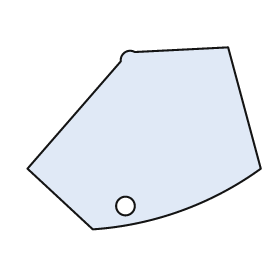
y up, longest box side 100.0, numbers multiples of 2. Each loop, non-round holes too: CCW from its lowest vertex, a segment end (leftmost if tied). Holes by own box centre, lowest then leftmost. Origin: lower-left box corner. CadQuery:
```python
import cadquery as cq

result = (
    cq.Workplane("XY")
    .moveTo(28.0, 0.0)
    .threePointArc((66.0, 8.0), (100.0, 26.0))
    .lineTo(86.0, 78.0)
    .lineTo(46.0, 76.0)
    .threePointArc((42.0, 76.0), (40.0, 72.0))
    .lineTo(0.0, 26.0)
    .close()
    .moveTo(42.0, 10.0)
    .circle(4.0)
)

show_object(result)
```